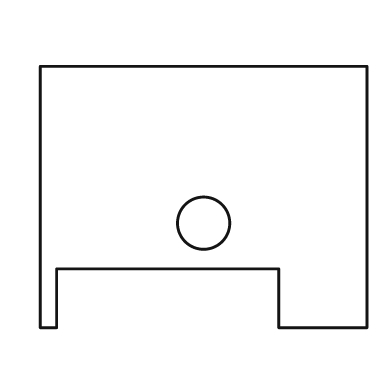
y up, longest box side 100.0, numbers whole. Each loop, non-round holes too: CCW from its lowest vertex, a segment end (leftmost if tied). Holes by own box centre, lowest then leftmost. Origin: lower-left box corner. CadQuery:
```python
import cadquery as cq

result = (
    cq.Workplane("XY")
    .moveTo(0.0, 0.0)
    .lineTo(5.0, 0.0)
    .lineTo(5.0, 18.0)
    .lineTo(73.0, 18.0)
    .lineTo(73.0, 0.0)
    .lineTo(100.0, 0.0)
    .lineTo(100.0, 80.0)
    .lineTo(0.0, 80.0)
    .close()
    .moveTo(50.0, 32.0)
    .circle(8.0)
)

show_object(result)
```